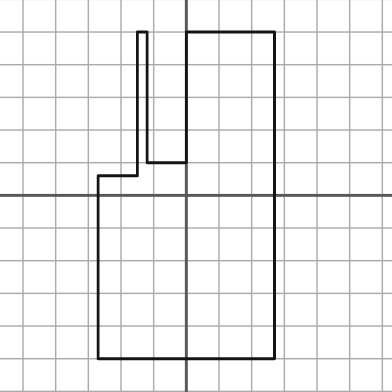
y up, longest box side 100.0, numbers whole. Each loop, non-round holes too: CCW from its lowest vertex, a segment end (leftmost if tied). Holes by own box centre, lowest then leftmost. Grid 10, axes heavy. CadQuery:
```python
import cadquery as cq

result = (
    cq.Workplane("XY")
    .moveTo(-27.0, -50.0)
    .lineTo(27.0, -50.0)
    .lineTo(27.0, 50.0)
    .lineTo(0.0, 50.0)
    .lineTo(0.0, 10.0)
    .lineTo(-12.0, 10.0)
    .lineTo(-12.0, 50.0)
    .lineTo(-15.0, 50.0)
    .lineTo(-15.0, 6.0)
    .lineTo(-27.0, 6.0)
    .close()
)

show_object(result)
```